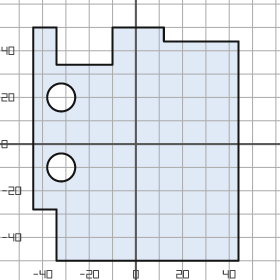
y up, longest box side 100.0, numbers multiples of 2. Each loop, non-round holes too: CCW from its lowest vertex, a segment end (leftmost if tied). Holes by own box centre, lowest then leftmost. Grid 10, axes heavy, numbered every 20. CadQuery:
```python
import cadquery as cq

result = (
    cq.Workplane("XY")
    .moveTo(-34.0, -50.0)
    .lineTo(44.0, -50.0)
    .lineTo(44.0, 44.0)
    .lineTo(12.0, 44.0)
    .lineTo(12.0, 50.0)
    .lineTo(-10.0, 50.0)
    .lineTo(-10.0, 34.0)
    .lineTo(-34.0, 34.0)
    .lineTo(-34.0, 50.0)
    .lineTo(-44.0, 50.0)
    .lineTo(-44.0, -28.0)
    .lineTo(-34.0, -28.0)
    .close()
    .moveTo(-32.0, -10.0)
    .circle(6.0)
    .moveTo(-32.0, 20.0)
    .circle(6.0)
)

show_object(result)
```